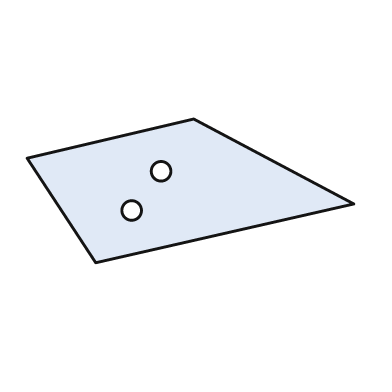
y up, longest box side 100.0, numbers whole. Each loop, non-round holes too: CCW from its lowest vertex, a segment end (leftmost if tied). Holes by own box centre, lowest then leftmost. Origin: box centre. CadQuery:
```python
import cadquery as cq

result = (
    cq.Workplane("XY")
    .moveTo(-29.0, -22.0)
    .lineTo(50.0, -4.0)
    .lineTo(1.0, 22.0)
    .lineTo(-50.0, 10.0)
    .close()
    .moveTo(-18.0, -6.0)
    .circle(3.0)
    .moveTo(-9.0, 6.0)
    .circle(3.0)
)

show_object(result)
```